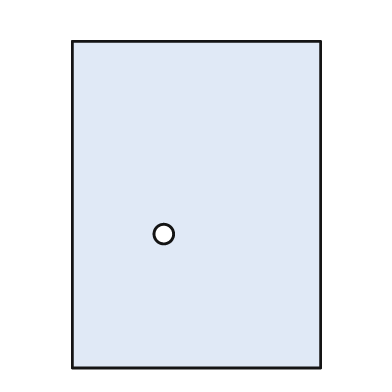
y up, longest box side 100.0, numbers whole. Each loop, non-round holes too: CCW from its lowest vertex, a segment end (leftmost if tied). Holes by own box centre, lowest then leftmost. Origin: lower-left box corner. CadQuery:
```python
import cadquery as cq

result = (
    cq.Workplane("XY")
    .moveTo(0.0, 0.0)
    .lineTo(76.0, 0.0)
    .lineTo(76.0, 100.0)
    .lineTo(0.0, 100.0)
    .close()
    .moveTo(28.0, 41.0)
    .circle(3.0)
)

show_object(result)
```